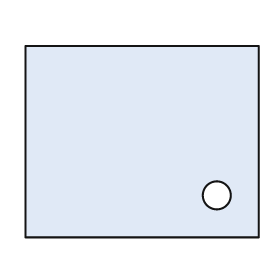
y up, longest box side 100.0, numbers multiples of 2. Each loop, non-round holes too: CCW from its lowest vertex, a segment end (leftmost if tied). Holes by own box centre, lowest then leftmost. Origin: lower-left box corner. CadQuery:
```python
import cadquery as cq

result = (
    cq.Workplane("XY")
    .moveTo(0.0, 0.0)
    .lineTo(100.0, 0.0)
    .lineTo(100.0, 82.0)
    .lineTo(0.0, 82.0)
    .close()
    .moveTo(82.0, 18.0)
    .circle(6.0)
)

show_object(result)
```